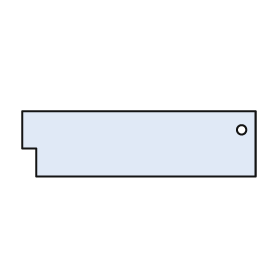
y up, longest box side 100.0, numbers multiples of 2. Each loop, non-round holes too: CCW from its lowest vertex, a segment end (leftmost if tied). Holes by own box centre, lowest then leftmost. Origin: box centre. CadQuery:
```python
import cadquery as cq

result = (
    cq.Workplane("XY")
    .moveTo(-44.0, -14.0)
    .lineTo(50.0, -14.0)
    .lineTo(50.0, 14.0)
    .lineTo(-50.0, 14.0)
    .lineTo(-50.0, -2.0)
    .lineTo(-44.0, -2.0)
    .close()
    .moveTo(44.0, 6.0)
    .circle(2.0)
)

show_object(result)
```